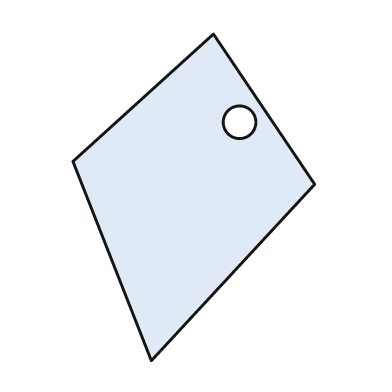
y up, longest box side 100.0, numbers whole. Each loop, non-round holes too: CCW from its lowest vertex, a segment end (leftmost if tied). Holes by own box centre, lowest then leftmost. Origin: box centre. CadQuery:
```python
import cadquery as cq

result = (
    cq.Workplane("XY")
    .moveTo(-13.0, -50.0)
    .lineTo(37.0, 4.0)
    .lineTo(6.0, 50.0)
    .lineTo(-37.0, 11.0)
    .close()
    .moveTo(14.0, 23.0)
    .circle(5.0)
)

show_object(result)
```